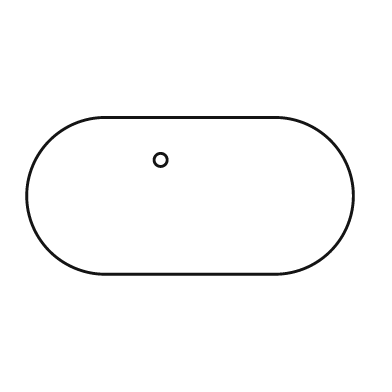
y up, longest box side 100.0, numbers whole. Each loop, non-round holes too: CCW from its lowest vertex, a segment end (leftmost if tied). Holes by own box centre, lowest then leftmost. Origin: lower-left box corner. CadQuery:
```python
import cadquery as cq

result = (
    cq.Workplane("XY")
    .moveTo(24.0, 0.0)
    .lineTo(76.0, 0.0)
    .threePointArc((100.0, 24.0), (76.0, 48.0))
    .lineTo(24.0, 48.0)
    .threePointArc((0.0, 24.0), (24.0, 0.0))
    .close()
    .moveTo(41.0, 35.0)
    .circle(2.0)
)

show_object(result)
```